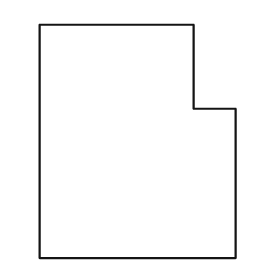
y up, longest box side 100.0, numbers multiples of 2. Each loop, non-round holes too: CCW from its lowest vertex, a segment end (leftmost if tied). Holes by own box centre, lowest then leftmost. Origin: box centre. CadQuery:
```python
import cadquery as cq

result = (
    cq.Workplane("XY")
    .moveTo(-42.0, -50.0)
    .lineTo(42.0, -50.0)
    .lineTo(42.0, 14.0)
    .lineTo(24.0, 14.0)
    .lineTo(24.0, 50.0)
    .lineTo(-42.0, 50.0)
    .close()
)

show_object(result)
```